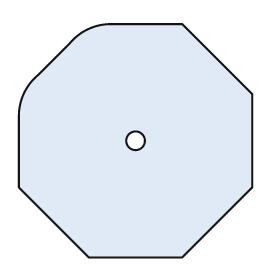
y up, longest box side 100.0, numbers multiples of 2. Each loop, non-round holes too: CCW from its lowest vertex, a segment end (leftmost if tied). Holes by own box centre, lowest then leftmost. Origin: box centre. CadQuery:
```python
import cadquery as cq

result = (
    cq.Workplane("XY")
    .moveTo(-20.0, -50.0)
    .lineTo(20.0, -50.0)
    .lineTo(50.0, -20.0)
    .lineTo(50.0, 20.0)
    .lineTo(20.0, 50.0)
    .lineTo(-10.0, 50.0)
    .threePointArc((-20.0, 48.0), (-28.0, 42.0))
    .lineTo(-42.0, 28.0)
    .threePointArc((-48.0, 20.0), (-50.0, 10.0))
    .lineTo(-50.0, -20.0)
    .close()
    .moveTo(0.0, 0.0)
    .circle(4.0)
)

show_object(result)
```